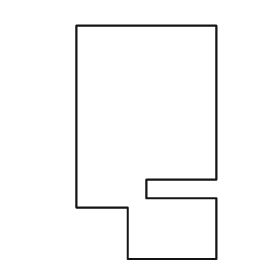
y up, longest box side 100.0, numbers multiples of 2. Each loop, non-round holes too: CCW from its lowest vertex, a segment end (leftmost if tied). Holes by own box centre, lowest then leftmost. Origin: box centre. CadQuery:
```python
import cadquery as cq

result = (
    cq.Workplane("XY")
    .moveTo(-8.0, -50.0)
    .lineTo(30.0, -50.0)
    .lineTo(30.0, -24.0)
    .lineTo(0.0, -24.0)
    .lineTo(0.0, -16.0)
    .lineTo(30.0, -16.0)
    .lineTo(30.0, 50.0)
    .lineTo(-30.0, 50.0)
    .lineTo(-30.0, -28.0)
    .lineTo(-8.0, -28.0)
    .close()
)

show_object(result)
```